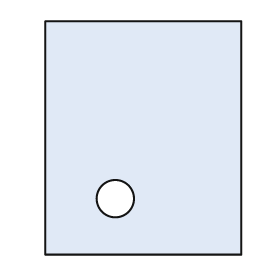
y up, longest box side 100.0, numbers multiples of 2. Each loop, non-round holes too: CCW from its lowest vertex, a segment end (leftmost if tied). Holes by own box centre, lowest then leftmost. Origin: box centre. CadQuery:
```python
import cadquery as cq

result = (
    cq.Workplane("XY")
    .moveTo(-42.0, -50.0)
    .lineTo(42.0, -50.0)
    .lineTo(42.0, 50.0)
    .lineTo(-42.0, 50.0)
    .close()
    .moveTo(-12.0, -26.0)
    .circle(8.0)
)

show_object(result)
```